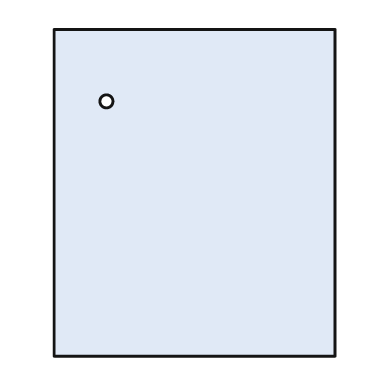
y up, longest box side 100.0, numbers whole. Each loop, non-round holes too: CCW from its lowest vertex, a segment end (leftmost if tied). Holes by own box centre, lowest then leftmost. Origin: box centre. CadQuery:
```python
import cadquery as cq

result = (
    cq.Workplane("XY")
    .moveTo(-43.0, -50.0)
    .lineTo(43.0, -50.0)
    .lineTo(43.0, 50.0)
    .lineTo(-43.0, 50.0)
    .close()
    .moveTo(-27.0, 28.0)
    .circle(2.0)
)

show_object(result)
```